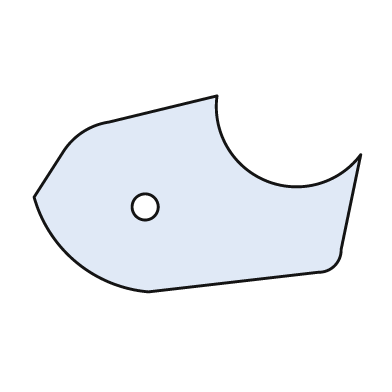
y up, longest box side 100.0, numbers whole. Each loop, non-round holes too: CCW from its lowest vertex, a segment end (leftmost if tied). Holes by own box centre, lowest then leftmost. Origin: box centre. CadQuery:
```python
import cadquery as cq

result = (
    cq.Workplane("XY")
    .moveTo(-15.0, -30.0)
    .lineTo(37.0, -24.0)
    .threePointArc((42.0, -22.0), (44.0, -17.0))
    .lineTo(50.0, 12.0)
    .threePointArc((21.0, 4.0), (6.0, 30.0))
    .lineTo(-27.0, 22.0)
    .threePointArc((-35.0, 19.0), (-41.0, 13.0))
    .lineTo(-50.0, -1.0)
    .threePointArc((-37.0, -21.0), (-15.0, -30.0))
    .close()
    .moveTo(-16.0, -4.0)
    .circle(4.0)
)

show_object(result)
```